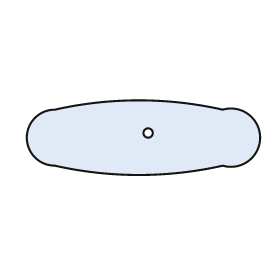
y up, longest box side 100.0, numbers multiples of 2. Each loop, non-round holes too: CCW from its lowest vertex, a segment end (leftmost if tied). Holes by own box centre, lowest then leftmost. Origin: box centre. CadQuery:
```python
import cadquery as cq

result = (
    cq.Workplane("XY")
    .moveTo(-38.0, -12.0)
    .threePointArc((-2.0, -16.0), (34.0, -12.0))
    .threePointArc((50.0, 0.0), (34.0, 12.0))
    .threePointArc((-2.0, 16.0), (-38.0, 12.0))
    .threePointArc((-50.0, 0.0), (-38.0, -12.0))
    .close()
    .moveTo(2.0, 2.0)
    .circle(2.0)
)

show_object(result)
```